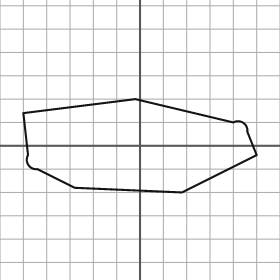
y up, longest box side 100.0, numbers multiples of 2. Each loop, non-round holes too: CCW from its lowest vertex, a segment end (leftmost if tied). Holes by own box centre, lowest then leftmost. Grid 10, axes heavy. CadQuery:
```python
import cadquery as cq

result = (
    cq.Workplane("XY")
    .moveTo(18.0, -20.0)
    .lineTo(50.0, -4.0)
    .lineTo(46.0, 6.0)
    .threePointArc((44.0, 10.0), (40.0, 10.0))
    .lineTo(-2.0, 20.0)
    .lineTo(-50.0, 14.0)
    .lineTo(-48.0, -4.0)
    .threePointArc((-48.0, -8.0), (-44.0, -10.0))
    .lineTo(-28.0, -18.0)
    .close()
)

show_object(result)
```